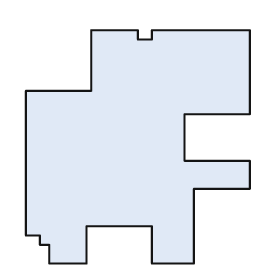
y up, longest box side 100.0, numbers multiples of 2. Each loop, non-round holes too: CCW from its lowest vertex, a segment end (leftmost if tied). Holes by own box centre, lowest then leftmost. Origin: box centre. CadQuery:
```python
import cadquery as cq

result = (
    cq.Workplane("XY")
    .moveTo(-38.0, -50.0)
    .lineTo(-22.0, -50.0)
    .lineTo(-22.0, -34.0)
    .lineTo(6.0, -34.0)
    .lineTo(6.0, -50.0)
    .lineTo(24.0, -50.0)
    .lineTo(24.0, -18.0)
    .lineTo(48.0, -18.0)
    .lineTo(48.0, -6.0)
    .lineTo(20.0, -6.0)
    .lineTo(20.0, 14.0)
    .lineTo(48.0, 14.0)
    .lineTo(48.0, 50.0)
    .lineTo(6.0, 50.0)
    .lineTo(6.0, 46.0)
    .lineTo(0.0, 46.0)
    .lineTo(0.0, 50.0)
    .lineTo(-20.0, 50.0)
    .lineTo(-20.0, 24.0)
    .lineTo(-48.0, 24.0)
    .lineTo(-48.0, -38.0)
    .lineTo(-42.0, -38.0)
    .lineTo(-42.0, -42.0)
    .lineTo(-38.0, -42.0)
    .close()
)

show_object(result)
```